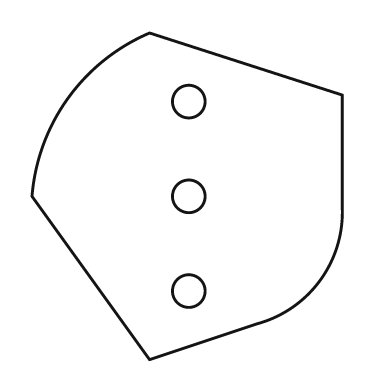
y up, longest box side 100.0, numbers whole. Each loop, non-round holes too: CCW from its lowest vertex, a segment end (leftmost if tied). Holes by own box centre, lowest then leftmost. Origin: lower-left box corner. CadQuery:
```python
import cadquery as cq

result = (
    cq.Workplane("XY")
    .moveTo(36.0, 0.0)
    .lineTo(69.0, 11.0)
    .threePointArc((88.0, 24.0), (95.0, 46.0))
    .lineTo(95.0, 81.0)
    .lineTo(36.0, 100.0)
    .threePointArc((11.0, 80.0), (0.0, 50.0))
    .close()
    .moveTo(48.0, 21.0)
    .circle(5.0)
    .moveTo(48.0, 50.0)
    .circle(5.0)
    .moveTo(48.0, 79.0)
    .circle(5.0)
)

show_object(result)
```